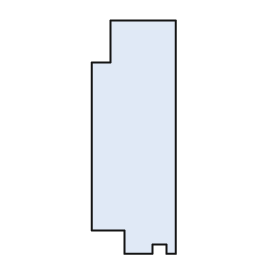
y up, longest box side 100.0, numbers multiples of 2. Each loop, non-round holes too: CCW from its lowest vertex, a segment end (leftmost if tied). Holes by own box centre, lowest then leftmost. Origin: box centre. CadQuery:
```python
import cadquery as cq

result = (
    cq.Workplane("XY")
    .moveTo(-4.0, -50.0)
    .lineTo(8.0, -50.0)
    .lineTo(8.0, -46.0)
    .lineTo(14.0, -46.0)
    .lineTo(14.0, -50.0)
    .lineTo(18.0, -50.0)
    .lineTo(18.0, 50.0)
    .lineTo(-10.0, 50.0)
    .lineTo(-10.0, 32.0)
    .lineTo(-18.0, 32.0)
    .lineTo(-18.0, -40.0)
    .lineTo(-4.0, -40.0)
    .close()
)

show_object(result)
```